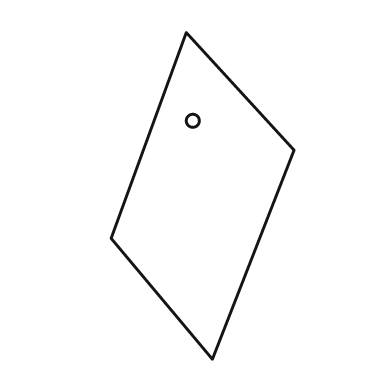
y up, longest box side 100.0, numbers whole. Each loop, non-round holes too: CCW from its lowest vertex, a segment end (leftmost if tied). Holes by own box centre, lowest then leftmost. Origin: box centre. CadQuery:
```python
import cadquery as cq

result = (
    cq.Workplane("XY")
    .moveTo(3.0, -50.0)
    .lineTo(28.0, 14.0)
    .lineTo(-5.0, 50.0)
    .lineTo(-28.0, -13.0)
    .close()
    .moveTo(-3.0, 23.0)
    .circle(2.0)
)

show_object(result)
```